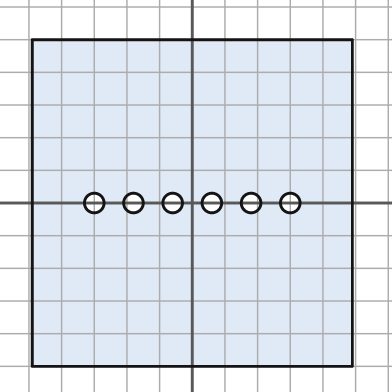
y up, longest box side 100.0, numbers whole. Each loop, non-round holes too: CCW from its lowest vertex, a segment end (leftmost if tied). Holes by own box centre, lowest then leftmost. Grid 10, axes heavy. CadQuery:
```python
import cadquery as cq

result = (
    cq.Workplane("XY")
    .moveTo(-49.0, -50.0)
    .lineTo(49.0, -50.0)
    .lineTo(49.0, 50.0)
    .lineTo(-49.0, 50.0)
    .close()
    .moveTo(-30.0, 0.0)
    .circle(3.0)
    .moveTo(-18.0, 0.0)
    .circle(3.0)
    .moveTo(-6.0, 0.0)
    .circle(3.0)
    .moveTo(6.0, 0.0)
    .circle(3.0)
    .moveTo(18.0, 0.0)
    .circle(3.0)
    .moveTo(30.0, 0.0)
    .circle(3.0)
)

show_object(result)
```